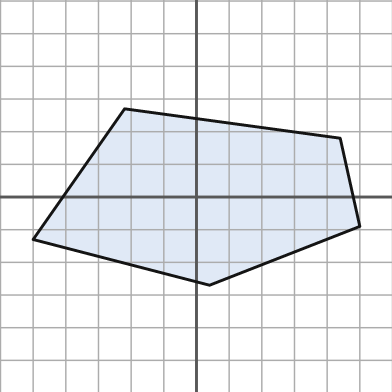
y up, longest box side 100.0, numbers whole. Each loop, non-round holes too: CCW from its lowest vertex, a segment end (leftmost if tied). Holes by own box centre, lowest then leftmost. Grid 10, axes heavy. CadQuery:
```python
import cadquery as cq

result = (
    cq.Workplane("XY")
    .moveTo(4.0, -27.0)
    .lineTo(50.0, -9.0)
    .lineTo(44.0, 18.0)
    .lineTo(-22.0, 27.0)
    .lineTo(-50.0, -13.0)
    .close()
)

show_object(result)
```